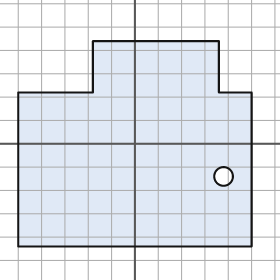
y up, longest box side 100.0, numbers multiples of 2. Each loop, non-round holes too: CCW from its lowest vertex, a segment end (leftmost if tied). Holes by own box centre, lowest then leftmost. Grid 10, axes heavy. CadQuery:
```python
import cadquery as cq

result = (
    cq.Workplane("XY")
    .moveTo(-50.0, -44.0)
    .lineTo(50.0, -44.0)
    .lineTo(50.0, 22.0)
    .lineTo(36.0, 22.0)
    .lineTo(36.0, 44.0)
    .lineTo(-18.0, 44.0)
    .lineTo(-18.0, 22.0)
    .lineTo(-50.0, 22.0)
    .close()
    .moveTo(38.0, -14.0)
    .circle(4.0)
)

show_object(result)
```